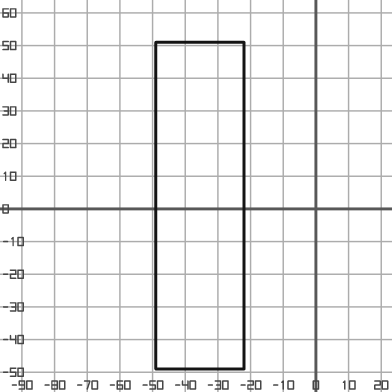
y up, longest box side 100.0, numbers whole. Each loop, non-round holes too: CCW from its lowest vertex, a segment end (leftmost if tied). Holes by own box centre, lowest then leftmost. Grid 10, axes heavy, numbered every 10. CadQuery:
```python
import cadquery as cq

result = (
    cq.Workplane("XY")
    .moveTo(-49.0, -49.0)
    .lineTo(-22.0, -49.0)
    .lineTo(-22.0, 51.0)
    .lineTo(-49.0, 51.0)
    .close()
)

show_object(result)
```